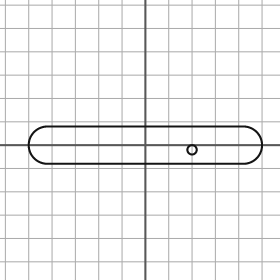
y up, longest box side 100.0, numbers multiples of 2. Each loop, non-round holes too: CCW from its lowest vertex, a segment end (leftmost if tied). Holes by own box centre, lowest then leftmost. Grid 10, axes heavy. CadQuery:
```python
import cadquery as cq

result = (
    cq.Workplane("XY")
    .moveTo(-42.0, -8.0)
    .lineTo(42.0, -8.0)
    .threePointArc((50.0, 0.0), (42.0, 8.0))
    .lineTo(-42.0, 8.0)
    .threePointArc((-50.0, 0.0), (-42.0, -8.0))
    .close()
    .moveTo(20.0, -2.0)
    .circle(2.0)
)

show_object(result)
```